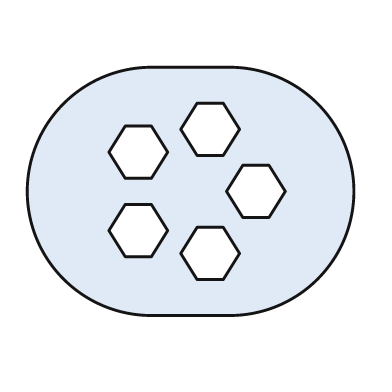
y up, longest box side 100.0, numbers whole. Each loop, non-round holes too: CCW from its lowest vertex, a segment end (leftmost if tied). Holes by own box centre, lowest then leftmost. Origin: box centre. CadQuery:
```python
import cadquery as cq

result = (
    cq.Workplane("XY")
    .moveTo(-12.0, -38.0)
    .lineTo(12.0, -38.0)
    .threePointArc((50.0, 0.0), (12.0, 38.0))
    .lineTo(-12.0, 38.0)
    .threePointArc((-50.0, 0.0), (-12.0, -38.0))
    .close()
    .moveTo(2.0, -27.0)
    .lineTo(10.0, -27.0)
    .lineTo(15.0, -19.0)
    .lineTo(10.0, -11.0)
    .lineTo(2.0, -11.0)
    .lineTo(-3.0, -19.0)
    .close()
    .moveTo(-20.0, -20.0)
    .lineTo(-12.0, -20.0)
    .lineTo(-7.0, -12.0)
    .lineTo(-12.0, -4.0)
    .lineTo(-20.0, -4.0)
    .lineTo(-25.0, -12.0)
    .close()
    .moveTo(16.0, -8.0)
    .lineTo(24.0, -8.0)
    .lineTo(29.0, 0.0)
    .lineTo(24.0, 8.0)
    .lineTo(16.0, 8.0)
    .lineTo(11.0, 0.0)
    .close()
    .moveTo(-20.0, 4.0)
    .lineTo(-12.0, 4.0)
    .lineTo(-7.0, 12.0)
    .lineTo(-12.0, 20.0)
    .lineTo(-20.0, 20.0)
    .lineTo(-25.0, 12.0)
    .close()
    .moveTo(2.0, 11.0)
    .lineTo(10.0, 11.0)
    .lineTo(15.0, 19.0)
    .lineTo(10.0, 27.0)
    .lineTo(2.0, 27.0)
    .lineTo(-3.0, 19.0)
    .close()
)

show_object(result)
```